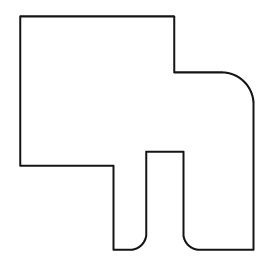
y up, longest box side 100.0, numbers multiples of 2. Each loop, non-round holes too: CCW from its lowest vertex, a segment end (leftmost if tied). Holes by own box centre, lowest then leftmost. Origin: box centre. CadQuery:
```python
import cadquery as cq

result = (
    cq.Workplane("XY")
    .moveTo(-10.0, -50.0)
    .lineTo(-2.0, -50.0)
    .threePointArc((2.0, -48.0), (4.0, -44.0))
    .lineTo(4.0, -8.0)
    .lineTo(20.0, -8.0)
    .lineTo(20.0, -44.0)
    .threePointArc((22.0, -48.0), (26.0, -50.0))
    .lineTo(50.0, -50.0)
    .lineTo(50.0, 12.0)
    .threePointArc((46.0, 22.0), (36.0, 26.0))
    .lineTo(16.0, 26.0)
    .lineTo(16.0, 50.0)
    .lineTo(-50.0, 50.0)
    .lineTo(-50.0, -14.0)
    .lineTo(-10.0, -14.0)
    .close()
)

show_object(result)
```